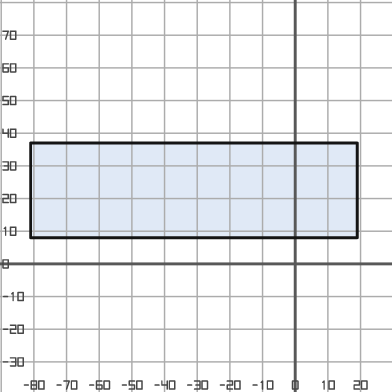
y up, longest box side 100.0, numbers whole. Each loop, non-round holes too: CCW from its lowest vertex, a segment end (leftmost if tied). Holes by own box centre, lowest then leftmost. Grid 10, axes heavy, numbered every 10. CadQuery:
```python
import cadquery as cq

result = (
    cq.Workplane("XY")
    .moveTo(-81.0, 8.0)
    .lineTo(19.0, 8.0)
    .lineTo(19.0, 37.0)
    .lineTo(-81.0, 37.0)
    .close()
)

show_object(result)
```